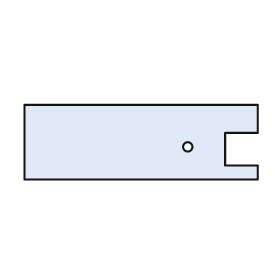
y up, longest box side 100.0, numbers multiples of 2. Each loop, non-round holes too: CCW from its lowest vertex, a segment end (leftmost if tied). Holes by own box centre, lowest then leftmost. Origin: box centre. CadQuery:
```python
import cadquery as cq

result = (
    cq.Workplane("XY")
    .moveTo(-50.0, -16.0)
    .lineTo(50.0, -16.0)
    .lineTo(50.0, -10.0)
    .lineTo(36.0, -10.0)
    .lineTo(36.0, 4.0)
    .lineTo(50.0, 4.0)
    .lineTo(50.0, 16.0)
    .lineTo(-50.0, 16.0)
    .close()
    .moveTo(20.0, -2.0)
    .circle(2.0)
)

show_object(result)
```